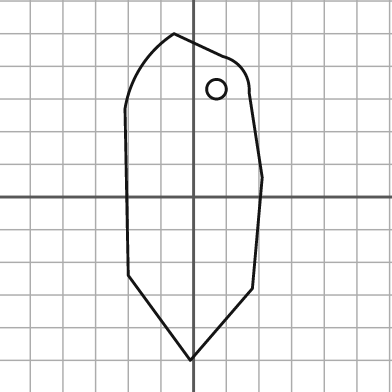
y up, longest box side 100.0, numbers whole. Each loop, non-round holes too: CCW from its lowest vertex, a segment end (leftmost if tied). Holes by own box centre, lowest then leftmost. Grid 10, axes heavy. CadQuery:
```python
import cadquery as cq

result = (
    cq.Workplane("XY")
    .moveTo(-1.0, -50.0)
    .lineTo(18.0, -28.0)
    .lineTo(21.0, 6.0)
    .lineTo(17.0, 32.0)
    .threePointArc((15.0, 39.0), (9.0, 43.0))
    .lineTo(-6.0, 50.0)
    .threePointArc((-16.0, 40.0), (-21.0, 27.0))
    .lineTo(-20.0, -24.0)
    .close()
    .moveTo(7.0, 33.0)
    .circle(3.0)
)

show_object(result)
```